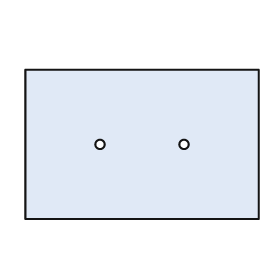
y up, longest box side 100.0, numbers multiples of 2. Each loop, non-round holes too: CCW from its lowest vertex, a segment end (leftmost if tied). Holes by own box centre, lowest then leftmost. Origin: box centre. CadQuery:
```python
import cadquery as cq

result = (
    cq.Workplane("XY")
    .moveTo(-50.0, -32.0)
    .lineTo(50.0, -32.0)
    .lineTo(50.0, 32.0)
    .lineTo(-50.0, 32.0)
    .close()
    .moveTo(-18.0, 0.0)
    .circle(2.0)
    .moveTo(18.0, 0.0)
    .circle(2.0)
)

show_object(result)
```